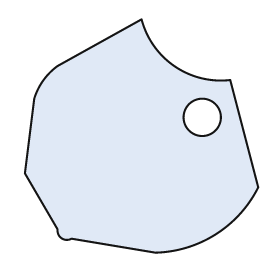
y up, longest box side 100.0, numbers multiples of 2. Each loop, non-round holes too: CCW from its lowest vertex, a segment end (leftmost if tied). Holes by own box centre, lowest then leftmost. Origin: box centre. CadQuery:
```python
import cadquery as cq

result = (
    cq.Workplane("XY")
    .moveTo(6.0, -50.0)
    .threePointArc((32.0, -42.0), (50.0, -22.0))
    .lineTo(38.0, 24.0)
    .threePointArc((14.0, 30.0), (0.0, 50.0))
    .lineTo(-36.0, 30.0)
    .threePointArc((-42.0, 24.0), (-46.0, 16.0))
    .lineTo(-50.0, -16.0)
    .lineTo(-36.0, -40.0)
    .threePointArc((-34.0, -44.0), (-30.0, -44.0))
    .close()
    .moveTo(26.0, 8.0)
    .circle(8.0)
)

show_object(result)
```